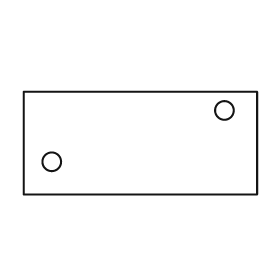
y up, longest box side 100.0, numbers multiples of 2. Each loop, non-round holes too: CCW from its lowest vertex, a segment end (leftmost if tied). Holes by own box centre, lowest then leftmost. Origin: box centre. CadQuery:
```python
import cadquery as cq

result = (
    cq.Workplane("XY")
    .moveTo(-50.0, -22.0)
    .lineTo(50.0, -22.0)
    .lineTo(50.0, 22.0)
    .lineTo(-50.0, 22.0)
    .close()
    .moveTo(-38.0, -8.0)
    .circle(4.0)
    .moveTo(36.0, 14.0)
    .circle(4.0)
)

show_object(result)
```